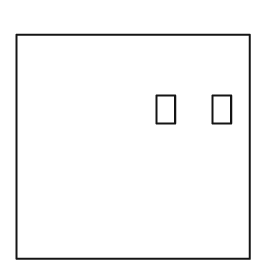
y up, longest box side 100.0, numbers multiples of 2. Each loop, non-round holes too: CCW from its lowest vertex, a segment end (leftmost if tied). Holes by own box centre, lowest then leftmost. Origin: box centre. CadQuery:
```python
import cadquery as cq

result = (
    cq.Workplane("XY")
    .moveTo(-50.0, -48.0)
    .lineTo(50.0, -48.0)
    .lineTo(50.0, 48.0)
    .lineTo(-50.0, 48.0)
    .close()
    .moveTo(10.0, 10.0)
    .lineTo(18.0, 10.0)
    .lineTo(18.0, 22.0)
    .lineTo(10.0, 22.0)
    .close()
    .moveTo(34.0, 10.0)
    .lineTo(42.0, 10.0)
    .lineTo(42.0, 22.0)
    .lineTo(34.0, 22.0)
    .close()
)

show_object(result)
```